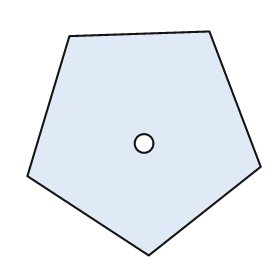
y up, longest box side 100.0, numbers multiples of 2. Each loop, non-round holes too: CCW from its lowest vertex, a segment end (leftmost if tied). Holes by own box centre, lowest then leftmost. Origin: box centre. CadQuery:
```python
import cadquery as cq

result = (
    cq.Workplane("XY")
    .moveTo(2.0, -48.0)
    .lineTo(50.0, -10.0)
    .lineTo(28.0, 48.0)
    .lineTo(-32.0, 46.0)
    .lineTo(-50.0, -14.0)
    .close()
    .moveTo(0.0, 0.0)
    .circle(4.0)
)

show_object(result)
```